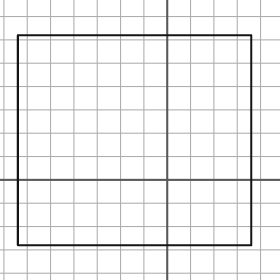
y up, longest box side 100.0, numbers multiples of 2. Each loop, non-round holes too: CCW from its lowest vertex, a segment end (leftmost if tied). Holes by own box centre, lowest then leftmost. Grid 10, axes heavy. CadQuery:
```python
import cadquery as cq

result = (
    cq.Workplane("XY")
    .moveTo(-64.0, -28.0)
    .lineTo(36.0, -28.0)
    .lineTo(36.0, 62.0)
    .lineTo(-64.0, 62.0)
    .close()
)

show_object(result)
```